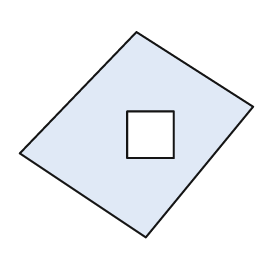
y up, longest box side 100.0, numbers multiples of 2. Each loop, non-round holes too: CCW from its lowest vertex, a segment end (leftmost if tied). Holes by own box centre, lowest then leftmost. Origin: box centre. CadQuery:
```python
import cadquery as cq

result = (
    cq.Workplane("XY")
    .moveTo(4.0, -44.0)
    .lineTo(50.0, 12.0)
    .lineTo(0.0, 44.0)
    .lineTo(-50.0, -8.0)
    .close()
    .moveTo(-4.0, -10.0)
    .lineTo(16.0, -10.0)
    .lineTo(16.0, 10.0)
    .lineTo(-4.0, 10.0)
    .close()
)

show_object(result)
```